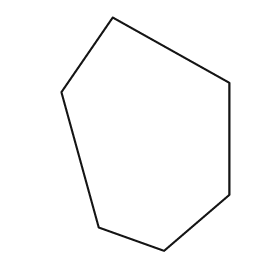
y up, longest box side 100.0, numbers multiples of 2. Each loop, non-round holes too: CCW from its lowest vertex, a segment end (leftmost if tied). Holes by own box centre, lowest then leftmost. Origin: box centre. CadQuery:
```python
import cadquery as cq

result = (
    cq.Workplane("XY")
    .moveTo(8.0, -50.0)
    .lineTo(36.0, -26.0)
    .lineTo(36.0, 22.0)
    .lineTo(-14.0, 50.0)
    .lineTo(-36.0, 18.0)
    .lineTo(-20.0, -40.0)
    .close()
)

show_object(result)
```